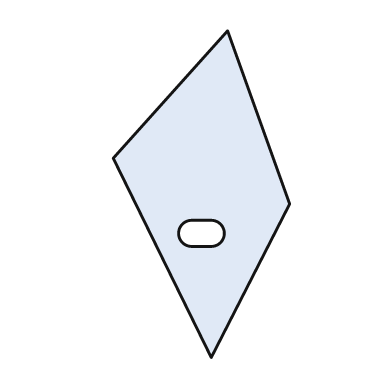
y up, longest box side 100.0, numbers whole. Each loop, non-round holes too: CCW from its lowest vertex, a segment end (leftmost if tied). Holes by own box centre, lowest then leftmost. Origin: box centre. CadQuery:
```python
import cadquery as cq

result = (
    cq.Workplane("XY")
    .moveTo(3.0, -50.0)
    .lineTo(27.0, -3.0)
    .lineTo(8.0, 50.0)
    .lineTo(-27.0, 11.0)
    .close()
    .moveTo(-3.0, -16.0)
    .lineTo(3.0, -16.0)
    .threePointArc((7.0, -12.0), (3.0, -8.0))
    .lineTo(-3.0, -8.0)
    .threePointArc((-7.0, -12.0), (-3.0, -16.0))
    .close()
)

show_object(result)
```